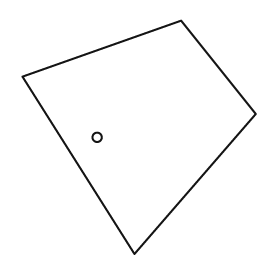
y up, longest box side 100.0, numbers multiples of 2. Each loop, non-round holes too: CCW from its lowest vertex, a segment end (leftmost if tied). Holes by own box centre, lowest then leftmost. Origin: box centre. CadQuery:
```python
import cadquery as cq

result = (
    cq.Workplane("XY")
    .moveTo(-2.0, -50.0)
    .lineTo(50.0, 10.0)
    .lineTo(18.0, 50.0)
    .lineTo(-50.0, 26.0)
    .close()
    .moveTo(-18.0, 0.0)
    .circle(2.0)
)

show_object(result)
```